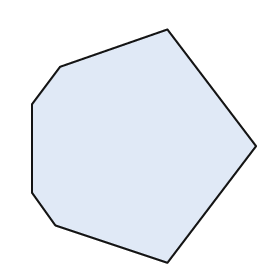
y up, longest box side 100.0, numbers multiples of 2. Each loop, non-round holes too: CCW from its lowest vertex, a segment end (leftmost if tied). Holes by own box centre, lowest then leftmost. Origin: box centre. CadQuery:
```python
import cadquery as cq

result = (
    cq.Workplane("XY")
    .moveTo(10.0, -50.0)
    .lineTo(48.0, 0.0)
    .lineTo(10.0, 50.0)
    .lineTo(-36.0, 34.0)
    .lineTo(-48.0, 18.0)
    .lineTo(-48.0, -20.0)
    .lineTo(-38.0, -34.0)
    .close()
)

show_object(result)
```